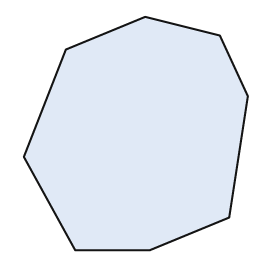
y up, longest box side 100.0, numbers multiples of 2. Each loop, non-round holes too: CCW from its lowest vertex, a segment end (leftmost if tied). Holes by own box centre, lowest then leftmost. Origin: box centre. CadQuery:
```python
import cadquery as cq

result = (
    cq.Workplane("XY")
    .moveTo(-26.0, -50.0)
    .lineTo(6.0, -50.0)
    .lineTo(40.0, -36.0)
    .lineTo(48.0, 16.0)
    .lineTo(36.0, 42.0)
    .lineTo(4.0, 50.0)
    .lineTo(-30.0, 36.0)
    .lineTo(-48.0, -10.0)
    .close()
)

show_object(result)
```